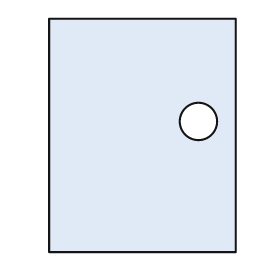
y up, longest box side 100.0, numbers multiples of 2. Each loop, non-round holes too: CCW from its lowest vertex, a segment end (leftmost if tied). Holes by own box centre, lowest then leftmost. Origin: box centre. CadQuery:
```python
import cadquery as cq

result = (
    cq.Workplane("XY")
    .moveTo(-40.0, -50.0)
    .lineTo(40.0, -50.0)
    .lineTo(40.0, 50.0)
    .lineTo(-40.0, 50.0)
    .close()
    .moveTo(24.0, 6.0)
    .circle(8.0)
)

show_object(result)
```